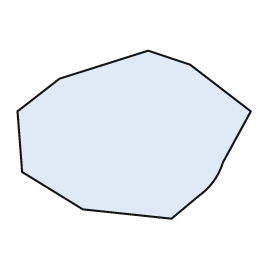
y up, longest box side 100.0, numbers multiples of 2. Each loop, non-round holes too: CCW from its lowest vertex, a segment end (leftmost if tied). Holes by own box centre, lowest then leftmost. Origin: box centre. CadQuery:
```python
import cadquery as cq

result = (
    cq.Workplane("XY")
    .moveTo(16.0, -36.0)
    .lineTo(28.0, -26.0)
    .threePointArc((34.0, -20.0), (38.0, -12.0))
    .lineTo(50.0, 10.0)
    .lineTo(24.0, 30.0)
    .lineTo(6.0, 36.0)
    .lineTo(-32.0, 24.0)
    .lineTo(-50.0, 10.0)
    .lineTo(-48.0, -16.0)
    .lineTo(-22.0, -32.0)
    .close()
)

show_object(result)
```